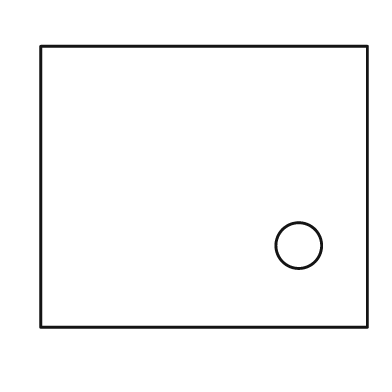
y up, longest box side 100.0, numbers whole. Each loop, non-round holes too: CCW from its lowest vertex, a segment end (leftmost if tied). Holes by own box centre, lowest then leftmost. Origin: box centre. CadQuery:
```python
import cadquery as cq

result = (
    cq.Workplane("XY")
    .moveTo(-50.0, -43.0)
    .lineTo(50.0, -43.0)
    .lineTo(50.0, 43.0)
    .lineTo(-50.0, 43.0)
    .close()
    .moveTo(29.0, -18.0)
    .circle(7.0)
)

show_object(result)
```